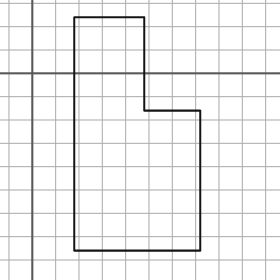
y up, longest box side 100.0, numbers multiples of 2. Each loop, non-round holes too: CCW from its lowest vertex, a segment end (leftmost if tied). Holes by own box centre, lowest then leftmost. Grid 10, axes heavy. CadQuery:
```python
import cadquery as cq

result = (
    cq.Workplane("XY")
    .moveTo(18.0, -76.0)
    .lineTo(72.0, -76.0)
    .lineTo(72.0, -16.0)
    .lineTo(48.0, -16.0)
    .lineTo(48.0, 24.0)
    .lineTo(18.0, 24.0)
    .close()
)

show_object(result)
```